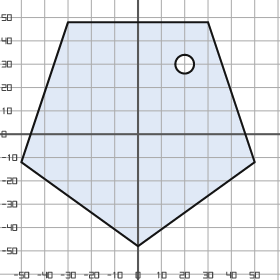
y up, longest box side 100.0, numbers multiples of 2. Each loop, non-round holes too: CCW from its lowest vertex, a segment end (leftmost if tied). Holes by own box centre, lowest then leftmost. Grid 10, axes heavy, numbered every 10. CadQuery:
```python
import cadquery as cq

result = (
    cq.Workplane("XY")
    .moveTo(0.0, -48.0)
    .lineTo(50.0, -12.0)
    .lineTo(30.0, 48.0)
    .lineTo(-30.0, 48.0)
    .lineTo(-50.0, -12.0)
    .close()
    .moveTo(20.0, 30.0)
    .circle(4.0)
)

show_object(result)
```